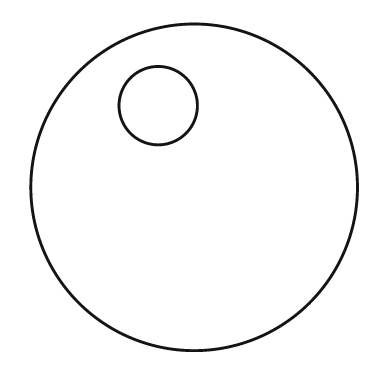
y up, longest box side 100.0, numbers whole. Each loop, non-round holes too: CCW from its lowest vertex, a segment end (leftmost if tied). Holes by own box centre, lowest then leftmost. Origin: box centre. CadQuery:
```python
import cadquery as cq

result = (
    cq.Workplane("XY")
    .moveTo(0.0, 0.0)
    .circle(50.0)
    .moveTo(-11.0, 25.0)
    .circle(12.0)
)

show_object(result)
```